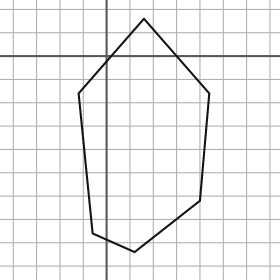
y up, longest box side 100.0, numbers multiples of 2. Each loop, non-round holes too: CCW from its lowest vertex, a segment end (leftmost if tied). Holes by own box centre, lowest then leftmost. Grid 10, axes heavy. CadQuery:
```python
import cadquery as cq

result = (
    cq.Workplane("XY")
    .moveTo(12.0, -84.0)
    .lineTo(40.0, -62.0)
    .lineTo(44.0, -16.0)
    .lineTo(16.0, 16.0)
    .lineTo(-12.0, -16.0)
    .lineTo(-6.0, -76.0)
    .close()
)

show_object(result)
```